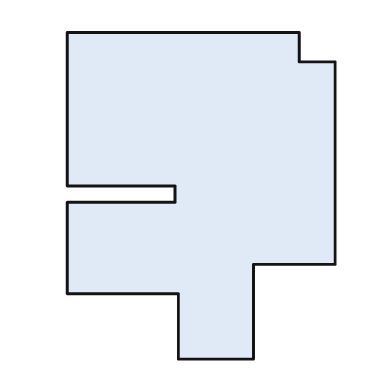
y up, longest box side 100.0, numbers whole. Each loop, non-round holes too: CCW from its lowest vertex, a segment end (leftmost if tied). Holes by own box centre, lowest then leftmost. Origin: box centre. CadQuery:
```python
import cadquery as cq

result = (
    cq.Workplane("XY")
    .moveTo(-7.0, -50.0)
    .lineTo(16.0, -50.0)
    .lineTo(16.0, -21.0)
    .lineTo(41.0, -21.0)
    .lineTo(41.0, 41.0)
    .lineTo(30.0, 41.0)
    .lineTo(30.0, 50.0)
    .lineTo(-41.0, 50.0)
    .lineTo(-41.0, 3.0)
    .lineTo(-8.0, 3.0)
    .lineTo(-8.0, -2.0)
    .lineTo(-41.0, -2.0)
    .lineTo(-41.0, -30.0)
    .lineTo(-7.0, -30.0)
    .close()
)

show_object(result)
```